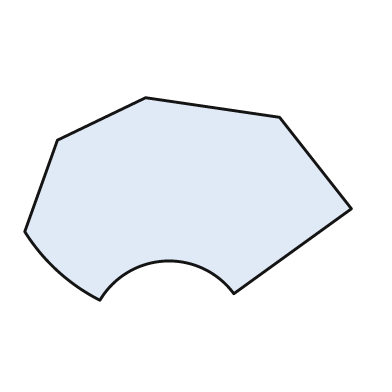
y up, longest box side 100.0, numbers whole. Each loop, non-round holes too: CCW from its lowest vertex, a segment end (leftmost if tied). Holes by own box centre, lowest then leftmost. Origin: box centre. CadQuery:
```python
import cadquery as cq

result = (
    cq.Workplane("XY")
    .moveTo(-27.0, -31.0)
    .threePointArc((-7.0, -19.0), (14.0, -29.0))
    .lineTo(50.0, -3.0)
    .lineTo(28.0, 25.0)
    .lineTo(-13.0, 31.0)
    .lineTo(-40.0, 18.0)
    .lineTo(-50.0, -10.0)
    .threePointArc((-40.0, -22.0), (-27.0, -31.0))
    .close()
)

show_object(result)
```